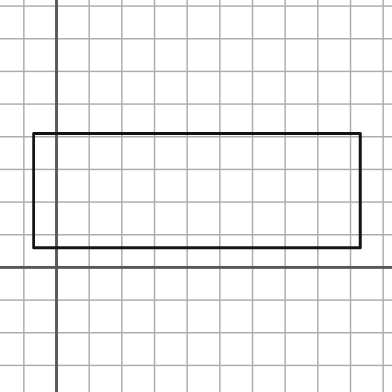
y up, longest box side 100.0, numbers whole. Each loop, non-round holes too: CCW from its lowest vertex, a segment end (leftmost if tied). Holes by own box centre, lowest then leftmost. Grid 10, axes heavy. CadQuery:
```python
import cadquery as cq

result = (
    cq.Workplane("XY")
    .moveTo(-7.0, 6.0)
    .lineTo(93.0, 6.0)
    .lineTo(93.0, 41.0)
    .lineTo(-7.0, 41.0)
    .close()
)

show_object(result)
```